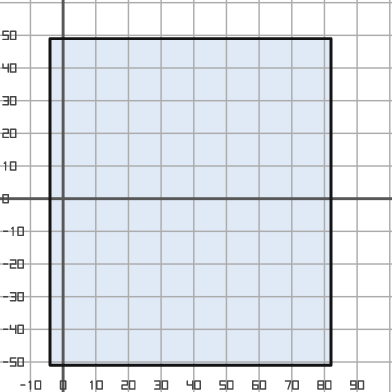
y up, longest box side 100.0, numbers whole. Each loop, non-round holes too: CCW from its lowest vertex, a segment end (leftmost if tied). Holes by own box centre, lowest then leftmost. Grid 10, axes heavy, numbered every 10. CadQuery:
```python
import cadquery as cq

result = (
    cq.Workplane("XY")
    .moveTo(-4.0, -51.0)
    .lineTo(82.0, -51.0)
    .lineTo(82.0, 49.0)
    .lineTo(-4.0, 49.0)
    .close()
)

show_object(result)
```